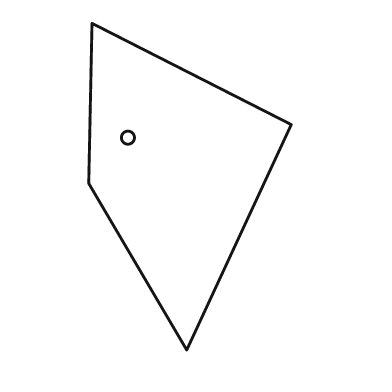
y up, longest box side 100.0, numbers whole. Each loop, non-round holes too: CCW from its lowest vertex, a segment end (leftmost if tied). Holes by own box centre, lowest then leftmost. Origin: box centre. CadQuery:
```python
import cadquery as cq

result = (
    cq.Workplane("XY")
    .moveTo(-1.0, -50.0)
    .lineTo(31.0, 19.0)
    .lineTo(-30.0, 50.0)
    .lineTo(-31.0, 1.0)
    .close()
    .moveTo(-19.0, 15.0)
    .circle(2.0)
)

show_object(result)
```